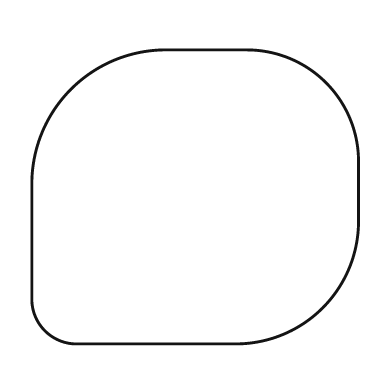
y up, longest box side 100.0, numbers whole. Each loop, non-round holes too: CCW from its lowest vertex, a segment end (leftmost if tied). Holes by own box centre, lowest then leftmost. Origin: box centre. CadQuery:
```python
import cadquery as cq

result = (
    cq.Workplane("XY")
    .moveTo(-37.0, -45.0)
    .lineTo(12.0, -45.0)
    .threePointArc((39.0, -34.0), (50.0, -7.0))
    .lineTo(50.0, 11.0)
    .threePointArc((40.0, 35.0), (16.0, 45.0))
    .lineTo(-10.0, 45.0)
    .threePointArc((-38.0, 33.0), (-50.0, 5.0))
    .lineTo(-50.0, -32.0)
    .threePointArc((-46.0, -41.0), (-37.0, -45.0))
    .close()
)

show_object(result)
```